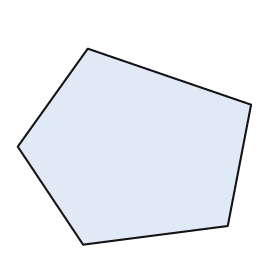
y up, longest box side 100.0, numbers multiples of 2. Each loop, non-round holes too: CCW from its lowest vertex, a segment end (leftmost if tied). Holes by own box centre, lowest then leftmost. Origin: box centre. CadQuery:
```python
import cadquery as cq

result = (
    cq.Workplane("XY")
    .moveTo(-22.0, -42.0)
    .lineTo(40.0, -34.0)
    .lineTo(50.0, 18.0)
    .lineTo(-20.0, 42.0)
    .lineTo(-50.0, 0.0)
    .close()
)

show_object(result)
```